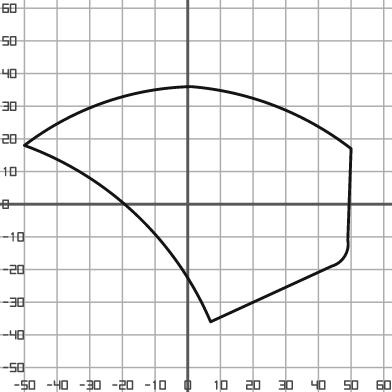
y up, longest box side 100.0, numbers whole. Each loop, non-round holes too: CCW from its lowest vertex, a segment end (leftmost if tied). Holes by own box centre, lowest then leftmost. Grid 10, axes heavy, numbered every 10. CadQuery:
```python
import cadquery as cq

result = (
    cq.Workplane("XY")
    .moveTo(7.0, -36.0)
    .lineTo(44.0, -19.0)
    .threePointArc((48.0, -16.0), (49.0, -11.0))
    .lineTo(50.0, 17.0)
    .threePointArc((27.0, 30.0), (1.0, 36.0))
    .threePointArc((-26.0, 31.0), (-50.0, 18.0))
    .threePointArc((-16.0, -3.0), (7.0, -36.0))
    .close()
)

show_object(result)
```